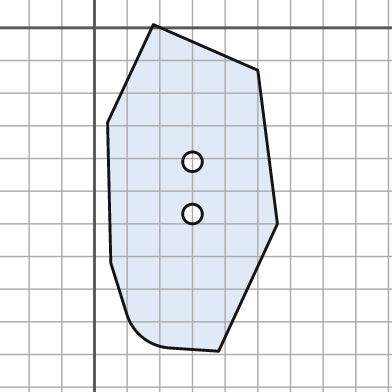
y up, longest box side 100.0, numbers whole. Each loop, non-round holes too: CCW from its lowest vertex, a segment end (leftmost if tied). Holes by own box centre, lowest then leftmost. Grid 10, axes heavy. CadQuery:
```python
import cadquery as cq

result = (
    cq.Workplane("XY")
    .moveTo(38.0, -99.0)
    .lineTo(56.0, -60.0)
    .lineTo(50.0, -13.0)
    .lineTo(18.0, 1.0)
    .lineTo(4.0, -29.0)
    .lineTo(5.0, -72.0)
    .lineTo(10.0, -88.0)
    .threePointArc((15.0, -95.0), (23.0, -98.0))
    .close()
    .moveTo(30.0, -57.0)
    .circle(3.0)
    .moveTo(30.0, -41.0)
    .circle(3.0)
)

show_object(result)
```